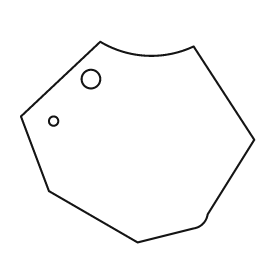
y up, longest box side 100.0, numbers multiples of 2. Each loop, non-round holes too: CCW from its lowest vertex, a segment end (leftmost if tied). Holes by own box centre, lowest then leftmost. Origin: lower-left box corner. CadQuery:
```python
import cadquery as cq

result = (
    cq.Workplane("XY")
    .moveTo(50.0, 0.0)
    .lineTo(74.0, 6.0)
    .threePointArc((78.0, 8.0), (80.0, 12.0))
    .lineTo(100.0, 44.0)
    .lineTo(74.0, 84.0)
    .threePointArc((54.0, 80.0), (34.0, 86.0))
    .lineTo(0.0, 54.0)
    .lineTo(12.0, 22.0)
    .close()
    .moveTo(14.0, 52.0)
    .circle(2.0)
    .moveTo(30.0, 70.0)
    .circle(4.0)
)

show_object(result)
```